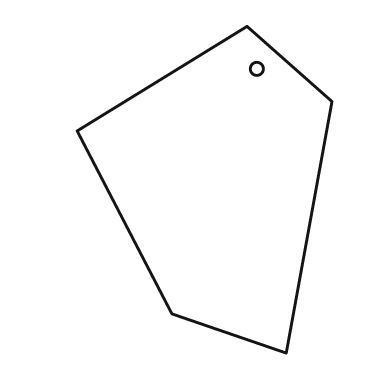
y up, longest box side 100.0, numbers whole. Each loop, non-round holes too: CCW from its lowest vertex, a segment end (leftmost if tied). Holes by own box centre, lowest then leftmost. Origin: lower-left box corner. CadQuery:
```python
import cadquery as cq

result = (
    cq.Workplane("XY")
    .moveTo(64.0, 0.0)
    .lineTo(78.0, 77.0)
    .lineTo(52.0, 100.0)
    .lineTo(0.0, 68.0)
    .lineTo(29.0, 12.0)
    .close()
    .moveTo(55.0, 87.0)
    .circle(2.0)
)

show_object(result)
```